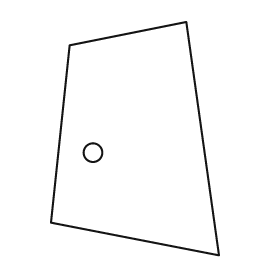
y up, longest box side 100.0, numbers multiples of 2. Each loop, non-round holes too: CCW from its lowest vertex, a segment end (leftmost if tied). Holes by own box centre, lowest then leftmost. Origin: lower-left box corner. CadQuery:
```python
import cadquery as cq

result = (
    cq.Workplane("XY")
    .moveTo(72.0, 0.0)
    .lineTo(58.0, 100.0)
    .lineTo(8.0, 90.0)
    .lineTo(0.0, 14.0)
    .close()
    .moveTo(18.0, 44.0)
    .circle(4.0)
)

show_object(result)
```